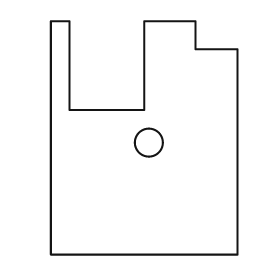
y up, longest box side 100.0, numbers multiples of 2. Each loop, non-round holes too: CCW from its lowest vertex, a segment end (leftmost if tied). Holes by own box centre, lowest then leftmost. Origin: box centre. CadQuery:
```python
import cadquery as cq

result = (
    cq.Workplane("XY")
    .moveTo(-40.0, -50.0)
    .lineTo(40.0, -50.0)
    .lineTo(40.0, 38.0)
    .lineTo(22.0, 38.0)
    .lineTo(22.0, 50.0)
    .lineTo(0.0, 50.0)
    .lineTo(0.0, 12.0)
    .lineTo(-32.0, 12.0)
    .lineTo(-32.0, 50.0)
    .lineTo(-40.0, 50.0)
    .close()
    .moveTo(2.0, -2.0)
    .circle(6.0)
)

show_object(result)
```